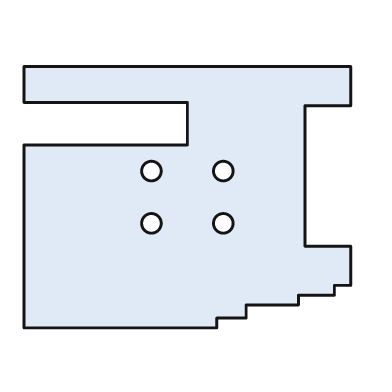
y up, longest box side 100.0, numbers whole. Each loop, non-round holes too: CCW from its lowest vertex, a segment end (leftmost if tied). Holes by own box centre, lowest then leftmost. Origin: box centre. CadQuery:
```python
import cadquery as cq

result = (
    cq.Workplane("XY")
    .moveTo(-50.0, -40.0)
    .lineTo(9.0, -40.0)
    .lineTo(9.0, -37.0)
    .lineTo(18.0, -37.0)
    .lineTo(18.0, -33.0)
    .lineTo(34.0, -33.0)
    .lineTo(34.0, -30.0)
    .lineTo(45.0, -30.0)
    .lineTo(45.0, -27.0)
    .lineTo(50.0, -27.0)
    .lineTo(50.0, -15.0)
    .lineTo(36.0, -15.0)
    .lineTo(36.0, 28.0)
    .lineTo(50.0, 28.0)
    .lineTo(50.0, 40.0)
    .lineTo(-50.0, 40.0)
    .lineTo(-50.0, 29.0)
    .lineTo(0.0, 29.0)
    .lineTo(0.0, 16.0)
    .lineTo(-50.0, 16.0)
    .close()
    .moveTo(-11.0, -8.0)
    .circle(3.0)
    .moveTo(11.0, -8.0)
    .circle(3.0)
    .moveTo(-11.0, 8.0)
    .circle(3.0)
    .moveTo(11.0, 8.0)
    .circle(3.0)
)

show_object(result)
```